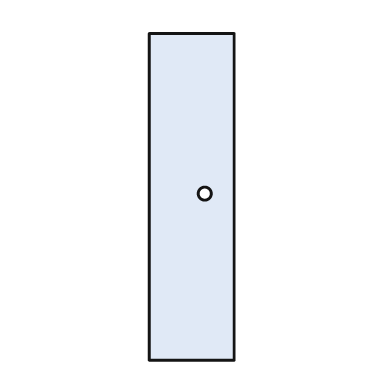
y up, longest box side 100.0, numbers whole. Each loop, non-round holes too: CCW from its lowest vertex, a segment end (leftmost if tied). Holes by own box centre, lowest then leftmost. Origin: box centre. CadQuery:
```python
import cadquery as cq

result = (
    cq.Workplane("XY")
    .moveTo(-13.0, -50.0)
    .lineTo(13.0, -50.0)
    .lineTo(13.0, 50.0)
    .lineTo(-13.0, 50.0)
    .close()
    .moveTo(4.0, 1.0)
    .circle(2.0)
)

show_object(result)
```